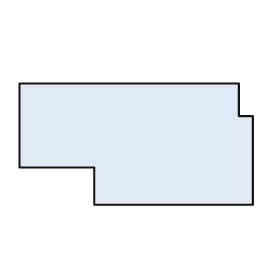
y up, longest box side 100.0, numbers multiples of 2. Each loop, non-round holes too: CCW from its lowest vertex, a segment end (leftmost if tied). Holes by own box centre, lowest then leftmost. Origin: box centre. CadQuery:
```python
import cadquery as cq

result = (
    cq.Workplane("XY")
    .moveTo(-18.0, -26.0)
    .lineTo(50.0, -26.0)
    .lineTo(50.0, 12.0)
    .lineTo(44.0, 12.0)
    .lineTo(44.0, 26.0)
    .lineTo(-50.0, 26.0)
    .lineTo(-50.0, -10.0)
    .lineTo(-18.0, -10.0)
    .close()
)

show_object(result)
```